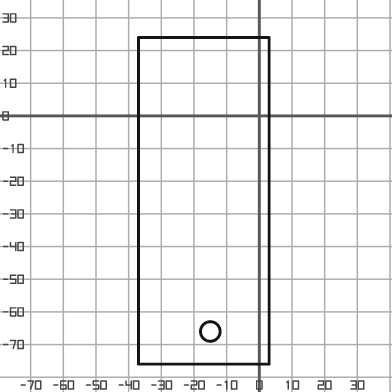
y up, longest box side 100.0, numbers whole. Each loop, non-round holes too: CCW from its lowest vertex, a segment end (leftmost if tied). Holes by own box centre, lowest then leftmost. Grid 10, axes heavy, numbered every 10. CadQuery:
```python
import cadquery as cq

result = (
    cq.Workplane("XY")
    .moveTo(-37.0, -76.0)
    .lineTo(3.0, -76.0)
    .lineTo(3.0, 24.0)
    .lineTo(-37.0, 24.0)
    .close()
    .moveTo(-15.0, -66.0)
    .circle(3.0)
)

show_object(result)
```